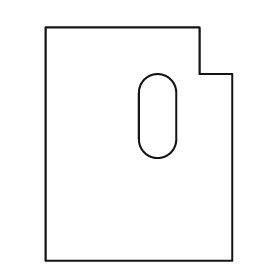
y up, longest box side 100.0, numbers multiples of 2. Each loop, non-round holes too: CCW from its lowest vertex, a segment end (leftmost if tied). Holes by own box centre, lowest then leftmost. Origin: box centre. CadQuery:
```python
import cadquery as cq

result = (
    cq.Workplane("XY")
    .moveTo(-40.0, -50.0)
    .lineTo(40.0, -50.0)
    .lineTo(40.0, 30.0)
    .lineTo(26.0, 30.0)
    .lineTo(26.0, 50.0)
    .lineTo(-40.0, 50.0)
    .close()
    .moveTo(0.0, 2.0)
    .threePointArc((8.0, -6.0), (16.0, 2.0))
    .lineTo(16.0, 22.0)
    .threePointArc((8.0, 30.0), (0.0, 22.0))
    .close()
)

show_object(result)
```